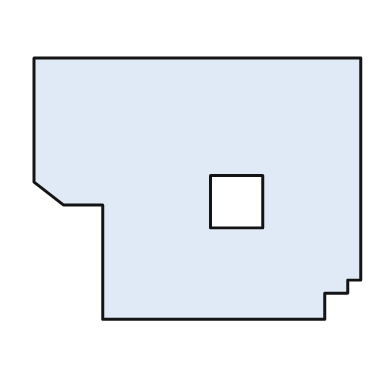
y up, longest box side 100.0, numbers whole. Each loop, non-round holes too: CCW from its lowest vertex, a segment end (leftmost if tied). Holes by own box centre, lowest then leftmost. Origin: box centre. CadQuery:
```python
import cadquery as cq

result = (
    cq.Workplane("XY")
    .moveTo(-29.0, -40.0)
    .lineTo(39.0, -40.0)
    .lineTo(39.0, -32.0)
    .lineTo(46.0, -32.0)
    .lineTo(46.0, -28.0)
    .lineTo(50.0, -28.0)
    .lineTo(50.0, 40.0)
    .lineTo(-50.0, 40.0)
    .lineTo(-50.0, 2.0)
    .lineTo(-41.0, -5.0)
    .lineTo(-29.0, -5.0)
    .close()
    .moveTo(4.0, -12.0)
    .lineTo(20.0, -12.0)
    .lineTo(20.0, 4.0)
    .lineTo(4.0, 4.0)
    .close()
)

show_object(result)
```